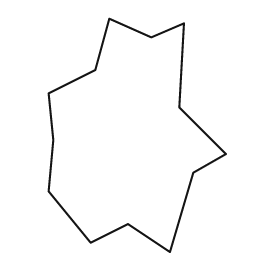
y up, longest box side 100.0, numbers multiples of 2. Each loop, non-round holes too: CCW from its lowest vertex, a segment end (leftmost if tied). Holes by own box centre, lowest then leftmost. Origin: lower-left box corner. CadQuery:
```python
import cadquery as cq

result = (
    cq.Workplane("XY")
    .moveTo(52.0, 0.0)
    .lineTo(62.0, 34.0)
    .lineTo(76.0, 42.0)
    .lineTo(56.0, 62.0)
    .lineTo(58.0, 98.0)
    .lineTo(44.0, 92.0)
    .lineTo(26.0, 100.0)
    .lineTo(20.0, 78.0)
    .lineTo(0.0, 68.0)
    .lineTo(2.0, 48.0)
    .lineTo(0.0, 26.0)
    .lineTo(18.0, 4.0)
    .lineTo(34.0, 12.0)
    .close()
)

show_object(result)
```